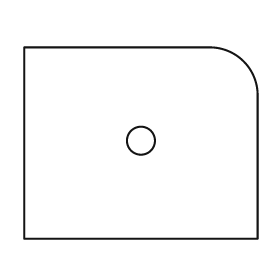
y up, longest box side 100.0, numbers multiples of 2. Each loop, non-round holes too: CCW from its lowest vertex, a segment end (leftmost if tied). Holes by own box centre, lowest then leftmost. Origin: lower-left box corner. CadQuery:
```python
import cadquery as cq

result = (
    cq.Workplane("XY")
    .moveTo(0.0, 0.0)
    .lineTo(100.0, 0.0)
    .lineTo(100.0, 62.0)
    .threePointArc((94.0, 76.0), (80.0, 82.0))
    .lineTo(0.0, 82.0)
    .close()
    .moveTo(50.0, 42.0)
    .circle(6.0)
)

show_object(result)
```